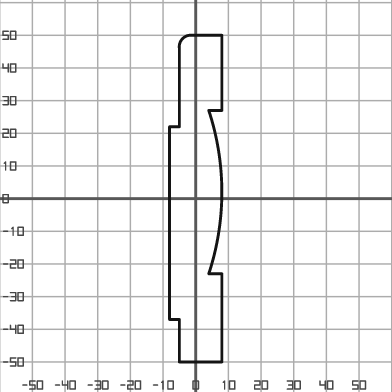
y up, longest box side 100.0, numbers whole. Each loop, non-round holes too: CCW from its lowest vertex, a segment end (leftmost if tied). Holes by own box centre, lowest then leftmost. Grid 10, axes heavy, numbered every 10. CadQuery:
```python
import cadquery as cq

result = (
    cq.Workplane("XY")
    .moveTo(-5.0, -50.0)
    .lineTo(8.0, -50.0)
    .lineTo(8.0, -23.0)
    .lineTo(4.0, -23.0)
    .threePointArc((8.0, 2.0), (4.0, 27.0))
    .lineTo(8.0, 27.0)
    .lineTo(8.0, 50.0)
    .lineTo(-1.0, 50.0)
    .threePointArc((-4.0, 49.0), (-5.0, 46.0))
    .lineTo(-5.0, 22.0)
    .lineTo(-8.0, 22.0)
    .lineTo(-8.0, -37.0)
    .lineTo(-5.0, -37.0)
    .close()
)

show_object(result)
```